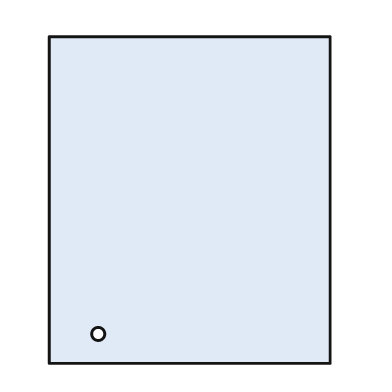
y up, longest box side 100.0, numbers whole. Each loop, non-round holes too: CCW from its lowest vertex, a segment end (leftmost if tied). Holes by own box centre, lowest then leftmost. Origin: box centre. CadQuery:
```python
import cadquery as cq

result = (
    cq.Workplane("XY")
    .moveTo(-43.0, -50.0)
    .lineTo(43.0, -50.0)
    .lineTo(43.0, 50.0)
    .lineTo(-43.0, 50.0)
    .close()
    .moveTo(-28.0, -41.0)
    .circle(2.0)
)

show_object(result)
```